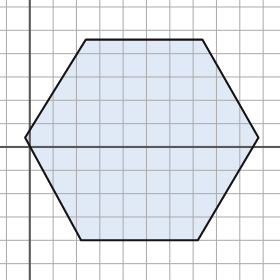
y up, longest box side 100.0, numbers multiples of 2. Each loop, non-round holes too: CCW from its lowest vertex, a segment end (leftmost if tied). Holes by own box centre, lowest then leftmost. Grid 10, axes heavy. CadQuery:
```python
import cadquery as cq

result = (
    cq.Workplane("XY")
    .moveTo(22.0, -40.0)
    .lineTo(72.0, -40.0)
    .lineTo(98.0, 4.0)
    .lineTo(74.0, 46.0)
    .lineTo(24.0, 46.0)
    .lineTo(-2.0, 4.0)
    .close()
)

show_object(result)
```